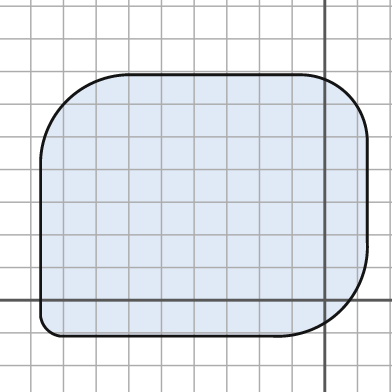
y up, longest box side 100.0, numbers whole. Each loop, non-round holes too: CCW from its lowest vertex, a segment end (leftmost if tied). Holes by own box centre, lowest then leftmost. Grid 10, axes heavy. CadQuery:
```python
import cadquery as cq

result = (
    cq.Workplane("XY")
    .moveTo(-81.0, -11.0)
    .lineTo(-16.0, -11.0)
    .threePointArc((5.0, -3.0), (13.0, 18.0))
    .lineTo(13.0, 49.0)
    .threePointArc((7.0, 63.0), (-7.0, 69.0))
    .lineTo(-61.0, 69.0)
    .threePointArc((-79.0, 61.0), (-87.0, 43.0))
    .lineTo(-87.0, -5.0)
    .threePointArc((-85.0, -9.0), (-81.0, -11.0))
    .close()
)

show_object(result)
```